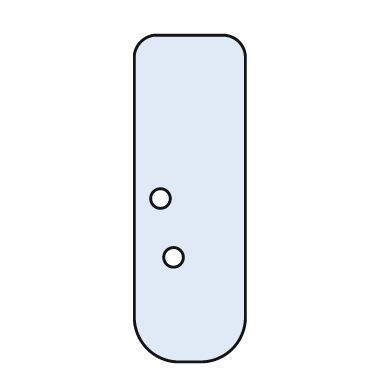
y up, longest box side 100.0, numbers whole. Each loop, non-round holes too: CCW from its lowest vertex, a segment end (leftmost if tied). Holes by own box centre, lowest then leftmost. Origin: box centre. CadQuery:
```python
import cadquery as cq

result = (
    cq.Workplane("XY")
    .moveTo(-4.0, -50.0)
    .lineTo(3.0, -50.0)
    .threePointArc((13.0, -46.0), (17.0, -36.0))
    .lineTo(17.0, 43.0)
    .threePointArc((15.0, 48.0), (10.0, 50.0))
    .lineTo(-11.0, 50.0)
    .threePointArc((-15.0, 48.0), (-17.0, 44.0))
    .lineTo(-17.0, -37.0)
    .threePointArc((-13.0, -46.0), (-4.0, -50.0))
    .close()
    .moveTo(-5.0, -18.0)
    .circle(3.0)
    .moveTo(-9.0, 0.0)
    .circle(3.0)
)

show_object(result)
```